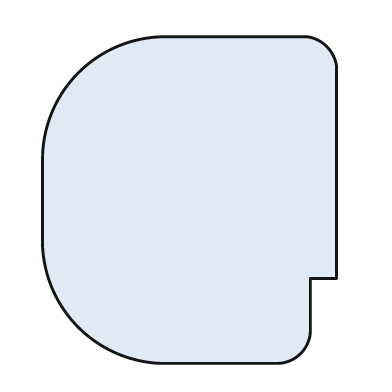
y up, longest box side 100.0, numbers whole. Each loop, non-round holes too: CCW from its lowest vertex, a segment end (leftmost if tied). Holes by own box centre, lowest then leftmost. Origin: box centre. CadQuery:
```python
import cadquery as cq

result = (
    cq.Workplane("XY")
    .moveTo(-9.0, -50.0)
    .lineTo(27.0, -50.0)
    .threePointArc((34.0, -47.0), (37.0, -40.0))
    .lineTo(37.0, -24.0)
    .lineTo(45.0, -24.0)
    .lineTo(45.0, 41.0)
    .threePointArc((42.0, 47.0), (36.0, 50.0))
    .lineTo(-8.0, 50.0)
    .threePointArc((-34.0, 39.0), (-45.0, 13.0))
    .lineTo(-45.0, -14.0)
    .threePointArc((-34.0, -39.0), (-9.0, -50.0))
    .close()
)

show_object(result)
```